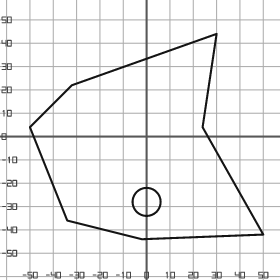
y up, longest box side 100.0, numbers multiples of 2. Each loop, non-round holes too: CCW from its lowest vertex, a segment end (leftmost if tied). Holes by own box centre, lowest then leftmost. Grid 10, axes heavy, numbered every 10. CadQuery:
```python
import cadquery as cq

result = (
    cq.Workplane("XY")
    .moveTo(-2.0, -44.0)
    .lineTo(50.0, -42.0)
    .lineTo(24.0, 4.0)
    .lineTo(30.0, 44.0)
    .lineTo(-32.0, 22.0)
    .lineTo(-50.0, 4.0)
    .lineTo(-34.0, -36.0)
    .close()
    .moveTo(0.0, -28.0)
    .circle(6.0)
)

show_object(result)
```